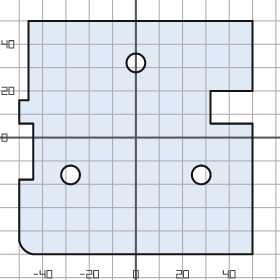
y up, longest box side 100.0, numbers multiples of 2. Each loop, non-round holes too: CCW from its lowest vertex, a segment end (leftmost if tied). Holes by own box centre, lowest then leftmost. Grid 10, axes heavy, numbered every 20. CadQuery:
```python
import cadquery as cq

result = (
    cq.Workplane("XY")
    .moveTo(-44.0, -50.0)
    .lineTo(50.0, -50.0)
    .lineTo(50.0, 6.0)
    .lineTo(32.0, 6.0)
    .lineTo(32.0, 20.0)
    .lineTo(50.0, 20.0)
    .lineTo(50.0, 50.0)
    .lineTo(-46.0, 50.0)
    .lineTo(-46.0, 16.0)
    .lineTo(-50.0, 16.0)
    .lineTo(-50.0, 6.0)
    .lineTo(-44.0, 6.0)
    .lineTo(-44.0, -18.0)
    .lineTo(-50.0, -18.0)
    .lineTo(-50.0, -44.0)
    .threePointArc((-48.0, -48.0), (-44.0, -50.0))
    .close()
    .moveTo(-28.0, -16.0)
    .circle(4.0)
    .moveTo(28.0, -16.0)
    .circle(4.0)
    .moveTo(0.0, 32.0)
    .circle(4.0)
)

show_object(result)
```